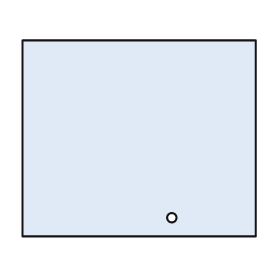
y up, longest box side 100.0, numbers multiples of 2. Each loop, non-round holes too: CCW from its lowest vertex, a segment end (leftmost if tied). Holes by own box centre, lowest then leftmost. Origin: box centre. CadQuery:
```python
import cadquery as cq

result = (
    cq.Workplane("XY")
    .moveTo(-50.0, -42.0)
    .lineTo(50.0, -42.0)
    .lineTo(50.0, 42.0)
    .lineTo(-50.0, 42.0)
    .close()
    .moveTo(14.0, -34.0)
    .circle(2.0)
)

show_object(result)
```